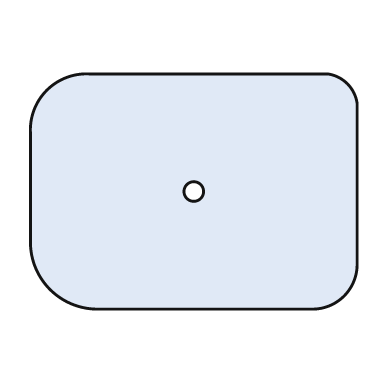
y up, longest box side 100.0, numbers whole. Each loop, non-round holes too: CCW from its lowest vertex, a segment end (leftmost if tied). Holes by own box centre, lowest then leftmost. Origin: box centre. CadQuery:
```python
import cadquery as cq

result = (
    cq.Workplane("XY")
    .moveTo(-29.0, -36.0)
    .lineTo(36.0, -36.0)
    .threePointArc((46.0, -32.0), (50.0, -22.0))
    .lineTo(50.0, 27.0)
    .threePointArc((47.0, 33.0), (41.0, 36.0))
    .lineTo(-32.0, 36.0)
    .threePointArc((-45.0, 31.0), (-50.0, 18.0))
    .lineTo(-50.0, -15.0)
    .threePointArc((-44.0, -30.0), (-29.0, -36.0))
    .close()
    .moveTo(0.0, 0.0)
    .circle(3.0)
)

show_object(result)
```